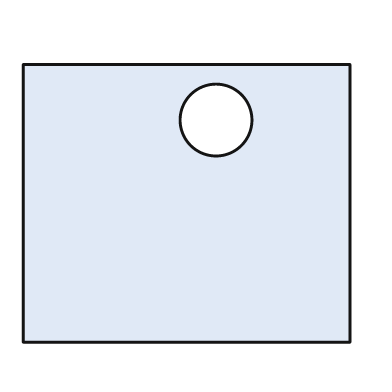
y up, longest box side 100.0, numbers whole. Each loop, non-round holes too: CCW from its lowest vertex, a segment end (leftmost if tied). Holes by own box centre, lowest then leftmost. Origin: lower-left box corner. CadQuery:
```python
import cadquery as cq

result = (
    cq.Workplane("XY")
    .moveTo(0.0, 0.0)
    .lineTo(100.0, 0.0)
    .lineTo(100.0, 85.0)
    .lineTo(0.0, 85.0)
    .close()
    .moveTo(59.0, 68.0)
    .circle(11.0)
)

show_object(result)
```